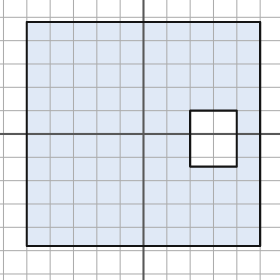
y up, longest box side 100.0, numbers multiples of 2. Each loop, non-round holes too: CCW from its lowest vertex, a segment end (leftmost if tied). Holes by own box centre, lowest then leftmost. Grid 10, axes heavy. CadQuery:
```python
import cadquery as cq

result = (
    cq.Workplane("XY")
    .moveTo(-50.0, -48.0)
    .lineTo(50.0, -48.0)
    .lineTo(50.0, 48.0)
    .lineTo(-50.0, 48.0)
    .close()
    .moveTo(20.0, -14.0)
    .lineTo(40.0, -14.0)
    .lineTo(40.0, 10.0)
    .lineTo(20.0, 10.0)
    .close()
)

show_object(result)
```